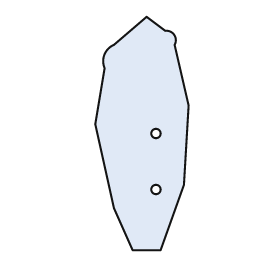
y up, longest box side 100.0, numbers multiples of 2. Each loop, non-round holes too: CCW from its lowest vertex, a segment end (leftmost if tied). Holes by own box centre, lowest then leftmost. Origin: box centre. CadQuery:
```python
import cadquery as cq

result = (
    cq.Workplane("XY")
    .moveTo(-4.0, -50.0)
    .lineTo(8.0, -50.0)
    .lineTo(18.0, -22.0)
    .lineTo(20.0, 12.0)
    .lineTo(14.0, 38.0)
    .threePointArc((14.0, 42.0), (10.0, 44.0))
    .lineTo(2.0, 50.0)
    .lineTo(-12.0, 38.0)
    .threePointArc((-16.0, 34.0), (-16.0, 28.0))
    .lineTo(-20.0, 4.0)
    .lineTo(-12.0, -32.0)
    .close()
    .moveTo(6.0, -24.0)
    .circle(2.0)
    .moveTo(6.0, 0.0)
    .circle(2.0)
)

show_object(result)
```